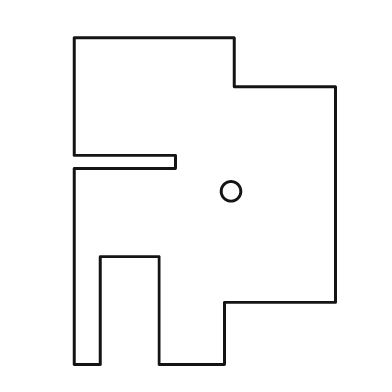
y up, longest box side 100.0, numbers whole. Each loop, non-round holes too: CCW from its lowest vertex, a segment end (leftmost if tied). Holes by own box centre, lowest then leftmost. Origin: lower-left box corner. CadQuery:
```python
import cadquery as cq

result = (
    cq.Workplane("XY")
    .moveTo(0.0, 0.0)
    .lineTo(8.0, 0.0)
    .lineTo(8.0, 33.0)
    .lineTo(26.0, 33.0)
    .lineTo(26.0, 0.0)
    .lineTo(46.0, 0.0)
    .lineTo(46.0, 19.0)
    .lineTo(80.0, 19.0)
    .lineTo(80.0, 85.0)
    .lineTo(49.0, 85.0)
    .lineTo(49.0, 100.0)
    .lineTo(0.0, 100.0)
    .lineTo(0.0, 64.0)
    .lineTo(31.0, 64.0)
    .lineTo(31.0, 60.0)
    .lineTo(0.0, 60.0)
    .close()
    .moveTo(48.0, 53.0)
    .circle(3.0)
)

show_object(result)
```